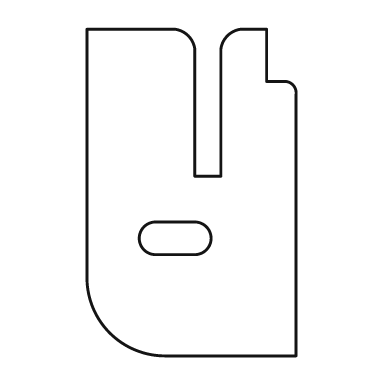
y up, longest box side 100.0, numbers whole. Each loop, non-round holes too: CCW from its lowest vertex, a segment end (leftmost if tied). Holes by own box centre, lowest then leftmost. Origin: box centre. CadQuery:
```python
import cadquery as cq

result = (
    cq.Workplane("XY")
    .moveTo(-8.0, -50.0)
    .lineTo(32.0, -50.0)
    .lineTo(32.0, 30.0)
    .threePointArc((31.0, 33.0), (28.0, 34.0))
    .lineTo(23.0, 34.0)
    .lineTo(23.0, 50.0)
    .lineTo(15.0, 50.0)
    .threePointArc((11.0, 48.0), (9.0, 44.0))
    .lineTo(9.0, 5.0)
    .lineTo(1.0, 5.0)
    .lineTo(1.0, 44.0)
    .threePointArc((-1.0, 48.0), (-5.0, 50.0))
    .lineTo(-32.0, 50.0)
    .lineTo(-32.0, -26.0)
    .threePointArc((-25.0, -43.0), (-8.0, -50.0))
    .close()
    .moveTo(-11.0, -19.0)
    .lineTo(1.0, -19.0)
    .threePointArc((6.0, -14.0), (1.0, -9.0))
    .lineTo(-11.0, -9.0)
    .threePointArc((-16.0, -14.0), (-11.0, -19.0))
    .close()
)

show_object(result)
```